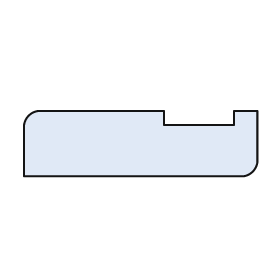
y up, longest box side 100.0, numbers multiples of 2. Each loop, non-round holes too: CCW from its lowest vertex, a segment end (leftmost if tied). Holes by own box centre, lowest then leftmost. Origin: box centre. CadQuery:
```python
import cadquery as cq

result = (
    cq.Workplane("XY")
    .moveTo(-50.0, -14.0)
    .lineTo(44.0, -14.0)
    .threePointArc((48.0, -12.0), (50.0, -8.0))
    .lineTo(50.0, 14.0)
    .lineTo(40.0, 14.0)
    .lineTo(40.0, 8.0)
    .lineTo(10.0, 8.0)
    .lineTo(10.0, 14.0)
    .lineTo(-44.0, 14.0)
    .threePointArc((-48.0, 12.0), (-50.0, 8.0))
    .close()
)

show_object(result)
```